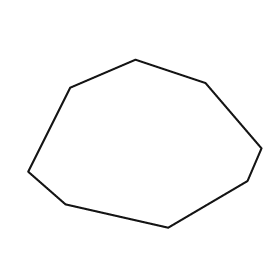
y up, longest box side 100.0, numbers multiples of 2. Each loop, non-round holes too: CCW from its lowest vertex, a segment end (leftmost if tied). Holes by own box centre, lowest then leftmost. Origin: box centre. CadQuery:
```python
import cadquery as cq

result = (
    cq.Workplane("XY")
    .moveTo(10.0, -36.0)
    .lineTo(44.0, -16.0)
    .lineTo(50.0, -2.0)
    .lineTo(26.0, 26.0)
    .lineTo(-4.0, 36.0)
    .lineTo(-32.0, 24.0)
    .lineTo(-50.0, -12.0)
    .lineTo(-34.0, -26.0)
    .close()
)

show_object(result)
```